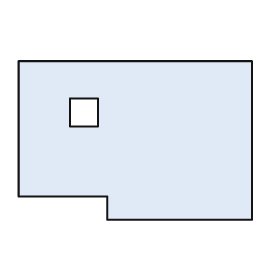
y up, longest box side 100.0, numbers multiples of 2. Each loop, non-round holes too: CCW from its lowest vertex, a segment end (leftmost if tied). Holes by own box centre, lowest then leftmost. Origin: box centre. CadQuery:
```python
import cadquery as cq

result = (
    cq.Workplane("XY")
    .moveTo(-12.0, -34.0)
    .lineTo(50.0, -34.0)
    .lineTo(50.0, 34.0)
    .lineTo(-50.0, 34.0)
    .lineTo(-50.0, -24.0)
    .lineTo(-12.0, -24.0)
    .close()
    .moveTo(-28.0, 6.0)
    .lineTo(-16.0, 6.0)
    .lineTo(-16.0, 18.0)
    .lineTo(-28.0, 18.0)
    .close()
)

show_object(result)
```